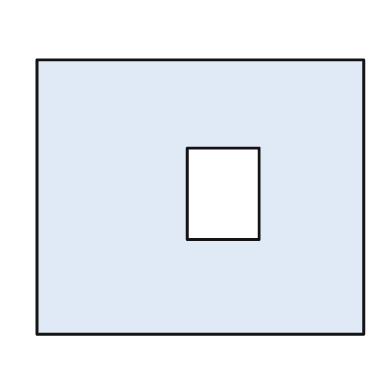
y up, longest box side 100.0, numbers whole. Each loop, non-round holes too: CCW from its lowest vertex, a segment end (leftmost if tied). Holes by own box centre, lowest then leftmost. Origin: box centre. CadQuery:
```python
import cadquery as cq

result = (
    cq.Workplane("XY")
    .moveTo(-50.0, -42.0)
    .lineTo(50.0, -42.0)
    .lineTo(50.0, 42.0)
    .lineTo(-50.0, 42.0)
    .close()
    .moveTo(-4.0, -13.0)
    .lineTo(18.0, -13.0)
    .lineTo(18.0, 15.0)
    .lineTo(-4.0, 15.0)
    .close()
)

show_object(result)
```